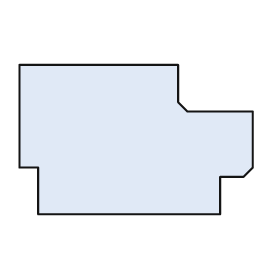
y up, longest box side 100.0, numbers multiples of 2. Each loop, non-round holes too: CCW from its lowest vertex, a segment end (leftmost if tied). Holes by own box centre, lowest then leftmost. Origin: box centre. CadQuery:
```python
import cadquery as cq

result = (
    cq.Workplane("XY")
    .moveTo(-42.0, -32.0)
    .lineTo(36.0, -32.0)
    .lineTo(36.0, -16.0)
    .lineTo(46.0, -16.0)
    .lineTo(50.0, -12.0)
    .lineTo(50.0, 12.0)
    .lineTo(22.0, 12.0)
    .lineTo(18.0, 16.0)
    .lineTo(18.0, 32.0)
    .lineTo(-50.0, 32.0)
    .lineTo(-50.0, -12.0)
    .lineTo(-42.0, -12.0)
    .close()
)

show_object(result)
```